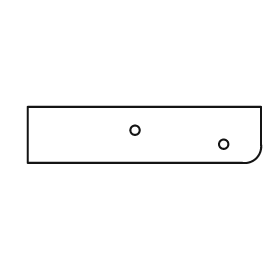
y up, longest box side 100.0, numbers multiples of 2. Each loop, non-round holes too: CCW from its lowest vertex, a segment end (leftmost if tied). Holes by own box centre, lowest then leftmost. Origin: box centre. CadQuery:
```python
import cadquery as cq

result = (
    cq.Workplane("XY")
    .moveTo(-50.0, -12.0)
    .lineTo(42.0, -12.0)
    .threePointArc((48.0, -10.0), (50.0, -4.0))
    .lineTo(50.0, 12.0)
    .lineTo(-50.0, 12.0)
    .close()
    .moveTo(34.0, -4.0)
    .circle(2.0)
    .moveTo(-4.0, 2.0)
    .circle(2.0)
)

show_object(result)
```